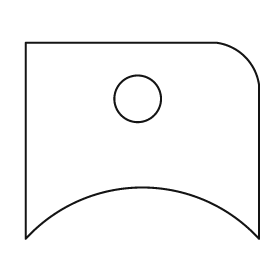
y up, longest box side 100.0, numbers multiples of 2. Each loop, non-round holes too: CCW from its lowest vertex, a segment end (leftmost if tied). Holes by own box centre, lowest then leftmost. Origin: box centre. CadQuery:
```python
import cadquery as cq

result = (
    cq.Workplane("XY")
    .moveTo(-50.0, -42.0)
    .threePointArc((0.0, -20.0), (50.0, -42.0))
    .lineTo(50.0, 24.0)
    .threePointArc((44.0, 36.0), (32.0, 42.0))
    .lineTo(-50.0, 42.0)
    .close()
    .moveTo(-2.0, 18.0)
    .circle(10.0)
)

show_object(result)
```